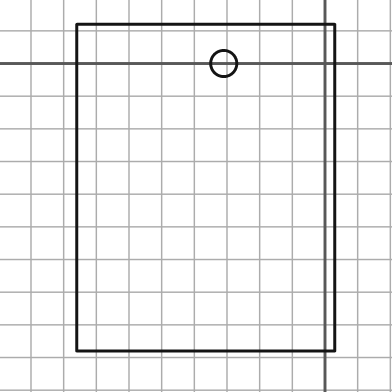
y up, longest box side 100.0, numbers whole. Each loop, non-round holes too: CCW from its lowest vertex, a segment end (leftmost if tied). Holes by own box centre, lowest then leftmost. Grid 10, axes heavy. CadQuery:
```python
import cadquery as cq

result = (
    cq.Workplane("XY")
    .moveTo(-76.0, -88.0)
    .lineTo(3.0, -88.0)
    .lineTo(3.0, 12.0)
    .lineTo(-76.0, 12.0)
    .close()
    .moveTo(-31.0, 0.0)
    .circle(4.0)
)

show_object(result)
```